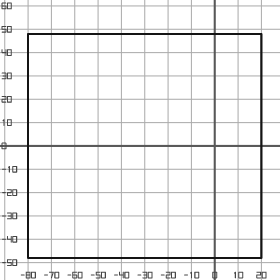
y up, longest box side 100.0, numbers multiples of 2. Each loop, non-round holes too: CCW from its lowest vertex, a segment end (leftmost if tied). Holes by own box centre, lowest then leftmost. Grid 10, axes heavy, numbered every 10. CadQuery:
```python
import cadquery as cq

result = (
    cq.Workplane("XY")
    .moveTo(-80.0, -48.0)
    .lineTo(20.0, -48.0)
    .lineTo(20.0, 48.0)
    .lineTo(-80.0, 48.0)
    .close()
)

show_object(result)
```